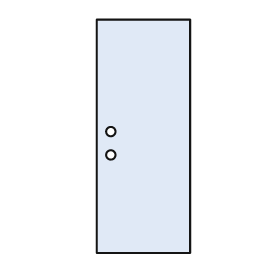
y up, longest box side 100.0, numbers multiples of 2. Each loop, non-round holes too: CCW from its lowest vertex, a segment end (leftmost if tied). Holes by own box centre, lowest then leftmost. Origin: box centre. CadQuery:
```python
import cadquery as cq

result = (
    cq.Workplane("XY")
    .moveTo(-20.0, -50.0)
    .lineTo(20.0, -50.0)
    .lineTo(20.0, 50.0)
    .lineTo(-20.0, 50.0)
    .close()
    .moveTo(-14.0, -8.0)
    .circle(2.0)
    .moveTo(-14.0, 2.0)
    .circle(2.0)
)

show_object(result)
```